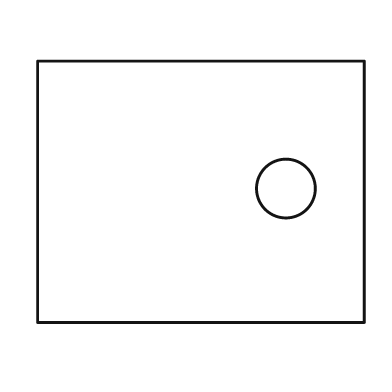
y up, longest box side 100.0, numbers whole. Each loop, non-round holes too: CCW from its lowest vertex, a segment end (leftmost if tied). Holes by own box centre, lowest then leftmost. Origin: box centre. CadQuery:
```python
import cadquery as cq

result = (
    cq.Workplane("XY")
    .moveTo(-50.0, -40.0)
    .lineTo(50.0, -40.0)
    .lineTo(50.0, 40.0)
    .lineTo(-50.0, 40.0)
    .close()
    .moveTo(26.0, 1.0)
    .circle(9.0)
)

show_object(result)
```